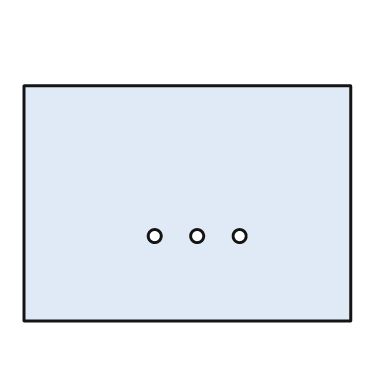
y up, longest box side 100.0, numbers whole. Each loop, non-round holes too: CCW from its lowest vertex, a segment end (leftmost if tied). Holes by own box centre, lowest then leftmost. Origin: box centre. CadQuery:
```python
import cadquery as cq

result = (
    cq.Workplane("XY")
    .moveTo(-50.0, -36.0)
    .lineTo(50.0, -36.0)
    .lineTo(50.0, 36.0)
    .lineTo(-50.0, 36.0)
    .close()
    .moveTo(-10.0, -10.0)
    .circle(2.0)
    .moveTo(3.0, -10.0)
    .circle(2.0)
    .moveTo(16.0, -10.0)
    .circle(2.0)
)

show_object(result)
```